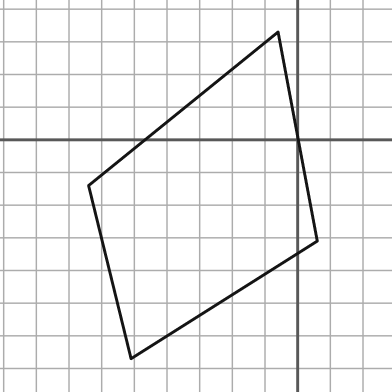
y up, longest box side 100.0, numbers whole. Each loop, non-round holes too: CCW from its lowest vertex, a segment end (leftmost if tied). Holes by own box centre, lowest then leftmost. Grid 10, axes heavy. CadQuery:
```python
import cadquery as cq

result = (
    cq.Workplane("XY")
    .moveTo(-51.0, -67.0)
    .lineTo(6.0, -31.0)
    .lineTo(-6.0, 33.0)
    .lineTo(-64.0, -14.0)
    .close()
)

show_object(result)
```